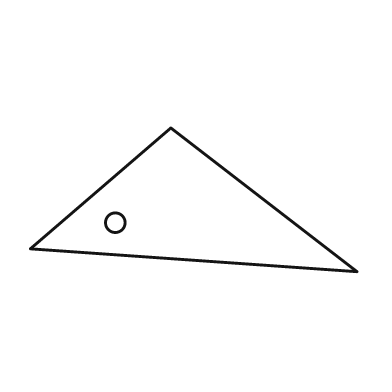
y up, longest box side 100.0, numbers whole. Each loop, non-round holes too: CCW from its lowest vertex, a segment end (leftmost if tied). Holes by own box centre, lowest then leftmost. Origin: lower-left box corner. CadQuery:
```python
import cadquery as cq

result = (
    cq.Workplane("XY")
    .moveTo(100.0, 0.0)
    .lineTo(43.0, 44.0)
    .lineTo(0.0, 7.0)
    .close()
    .moveTo(26.0, 15.0)
    .circle(3.0)
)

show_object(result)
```